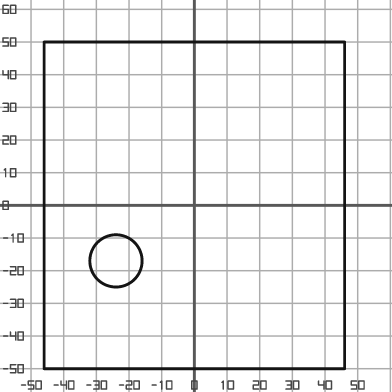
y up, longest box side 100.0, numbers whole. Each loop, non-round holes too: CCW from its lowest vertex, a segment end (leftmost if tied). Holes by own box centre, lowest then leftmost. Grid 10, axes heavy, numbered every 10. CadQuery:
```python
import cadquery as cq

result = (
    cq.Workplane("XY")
    .moveTo(-46.0, -50.0)
    .lineTo(46.0, -50.0)
    .lineTo(46.0, 50.0)
    .lineTo(-46.0, 50.0)
    .close()
    .moveTo(-24.0, -17.0)
    .circle(8.0)
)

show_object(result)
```